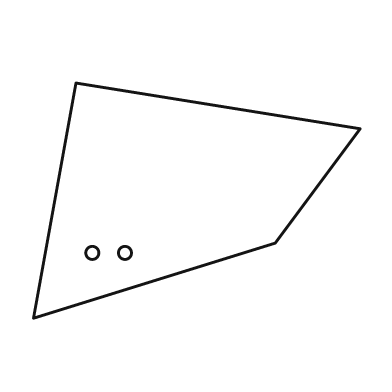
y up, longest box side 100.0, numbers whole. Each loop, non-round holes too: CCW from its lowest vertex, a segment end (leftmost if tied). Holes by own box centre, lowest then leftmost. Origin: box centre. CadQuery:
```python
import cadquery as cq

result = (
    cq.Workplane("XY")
    .moveTo(-50.0, -36.0)
    .lineTo(24.0, -13.0)
    .lineTo(50.0, 22.0)
    .lineTo(-37.0, 36.0)
    .close()
    .moveTo(-32.0, -16.0)
    .circle(2.0)
    .moveTo(-22.0, -16.0)
    .circle(2.0)
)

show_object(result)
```